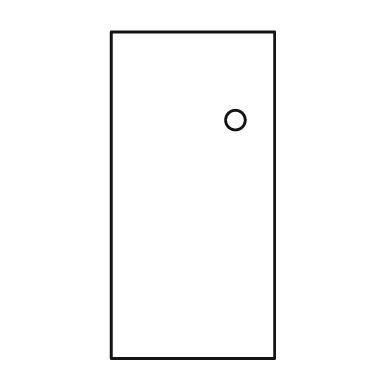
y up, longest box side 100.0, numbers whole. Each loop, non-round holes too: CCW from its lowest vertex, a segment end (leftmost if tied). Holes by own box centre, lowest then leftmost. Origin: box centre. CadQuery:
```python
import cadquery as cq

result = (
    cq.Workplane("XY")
    .moveTo(-25.0, -50.0)
    .lineTo(25.0, -50.0)
    .lineTo(25.0, 50.0)
    .lineTo(-25.0, 50.0)
    .close()
    .moveTo(13.0, 23.0)
    .circle(3.0)
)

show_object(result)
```